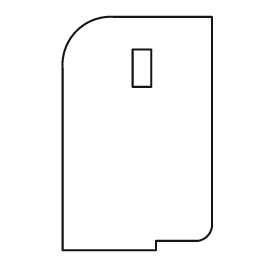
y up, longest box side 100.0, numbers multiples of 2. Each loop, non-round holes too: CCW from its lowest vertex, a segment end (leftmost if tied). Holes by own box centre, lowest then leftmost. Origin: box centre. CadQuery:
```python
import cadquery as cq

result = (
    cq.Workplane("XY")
    .moveTo(-32.0, -50.0)
    .lineTo(8.0, -50.0)
    .lineTo(8.0, -46.0)
    .lineTo(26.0, -46.0)
    .threePointArc((30.0, -44.0), (32.0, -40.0))
    .lineTo(32.0, 50.0)
    .lineTo(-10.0, 50.0)
    .threePointArc((-26.0, 44.0), (-32.0, 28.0))
    .close()
    .moveTo(-2.0, 20.0)
    .lineTo(6.0, 20.0)
    .lineTo(6.0, 36.0)
    .lineTo(-2.0, 36.0)
    .close()
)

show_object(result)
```